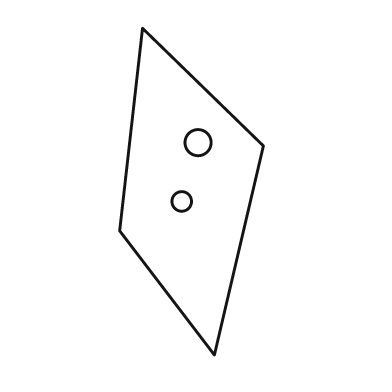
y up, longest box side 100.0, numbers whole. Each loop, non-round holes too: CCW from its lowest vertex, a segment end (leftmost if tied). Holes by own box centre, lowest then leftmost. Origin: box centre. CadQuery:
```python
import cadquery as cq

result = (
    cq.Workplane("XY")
    .moveTo(7.0, -50.0)
    .lineTo(22.0, 14.0)
    .lineTo(-15.0, 50.0)
    .lineTo(-22.0, -12.0)
    .close()
    .moveTo(-3.0, -3.0)
    .circle(3.0)
    .moveTo(2.0, 15.0)
    .circle(4.0)
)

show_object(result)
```